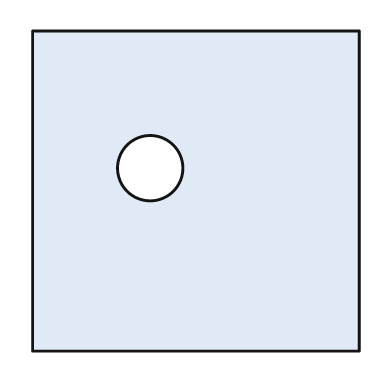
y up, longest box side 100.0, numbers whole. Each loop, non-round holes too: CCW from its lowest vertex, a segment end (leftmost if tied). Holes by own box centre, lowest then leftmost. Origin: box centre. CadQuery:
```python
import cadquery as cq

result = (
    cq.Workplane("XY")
    .moveTo(-50.0, -49.0)
    .lineTo(50.0, -49.0)
    .lineTo(50.0, 49.0)
    .lineTo(-50.0, 49.0)
    .close()
    .moveTo(-14.0, 7.0)
    .circle(10.0)
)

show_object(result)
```